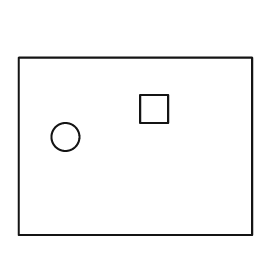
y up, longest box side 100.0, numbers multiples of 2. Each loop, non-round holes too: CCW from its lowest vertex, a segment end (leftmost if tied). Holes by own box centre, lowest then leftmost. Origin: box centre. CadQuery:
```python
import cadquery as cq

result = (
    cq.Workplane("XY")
    .moveTo(-50.0, -38.0)
    .lineTo(50.0, -38.0)
    .lineTo(50.0, 38.0)
    .lineTo(-50.0, 38.0)
    .close()
    .moveTo(-30.0, 4.0)
    .circle(6.0)
    .moveTo(2.0, 10.0)
    .lineTo(14.0, 10.0)
    .lineTo(14.0, 22.0)
    .lineTo(2.0, 22.0)
    .close()
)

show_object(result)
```